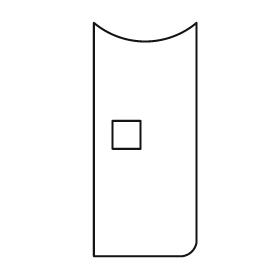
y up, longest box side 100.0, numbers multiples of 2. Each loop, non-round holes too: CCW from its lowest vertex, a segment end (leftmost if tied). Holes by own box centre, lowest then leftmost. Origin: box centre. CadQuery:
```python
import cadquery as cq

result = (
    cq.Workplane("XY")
    .moveTo(-22.0, -50.0)
    .lineTo(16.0, -50.0)
    .threePointArc((20.0, -48.0), (22.0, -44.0))
    .lineTo(22.0, 50.0)
    .threePointArc((0.0, 42.0), (-22.0, 50.0))
    .close()
    .moveTo(-14.0, -4.0)
    .lineTo(-2.0, -4.0)
    .lineTo(-2.0, 8.0)
    .lineTo(-14.0, 8.0)
    .close()
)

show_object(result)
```